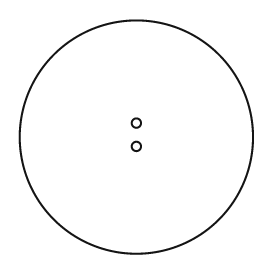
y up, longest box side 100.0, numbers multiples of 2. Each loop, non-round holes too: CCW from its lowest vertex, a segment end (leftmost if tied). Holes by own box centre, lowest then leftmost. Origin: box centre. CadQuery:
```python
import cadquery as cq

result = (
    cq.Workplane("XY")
    .moveTo(0.0, 0.0)
    .circle(50.0)
    .moveTo(0.0, -4.0)
    .circle(2.0)
    .moveTo(0.0, 6.0)
    .circle(2.0)
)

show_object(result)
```